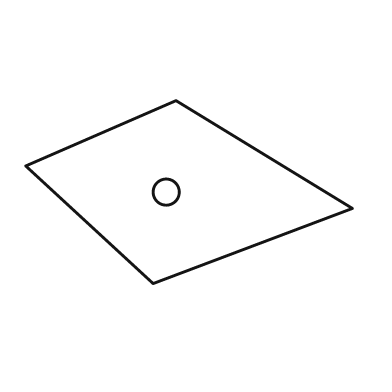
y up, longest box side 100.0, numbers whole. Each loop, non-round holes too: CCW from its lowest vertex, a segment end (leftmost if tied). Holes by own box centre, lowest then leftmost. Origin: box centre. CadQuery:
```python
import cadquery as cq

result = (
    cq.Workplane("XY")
    .moveTo(-11.0, -28.0)
    .lineTo(50.0, -5.0)
    .lineTo(-4.0, 28.0)
    .lineTo(-50.0, 8.0)
    .close()
    .moveTo(-7.0, 0.0)
    .circle(4.0)
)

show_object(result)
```